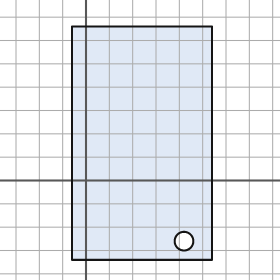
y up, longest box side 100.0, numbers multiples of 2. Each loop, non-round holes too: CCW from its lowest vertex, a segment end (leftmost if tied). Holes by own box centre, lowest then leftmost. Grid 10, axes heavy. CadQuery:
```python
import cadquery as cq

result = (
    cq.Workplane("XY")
    .moveTo(-6.0, -34.0)
    .lineTo(54.0, -34.0)
    .lineTo(54.0, 66.0)
    .lineTo(-6.0, 66.0)
    .close()
    .moveTo(42.0, -26.0)
    .circle(4.0)
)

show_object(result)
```